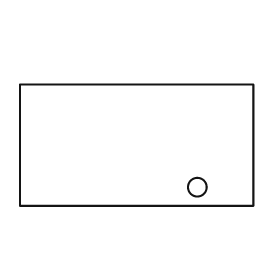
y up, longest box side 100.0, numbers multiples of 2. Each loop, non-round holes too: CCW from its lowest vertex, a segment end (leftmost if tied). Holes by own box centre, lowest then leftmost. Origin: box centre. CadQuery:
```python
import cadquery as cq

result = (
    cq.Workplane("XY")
    .moveTo(-50.0, -26.0)
    .lineTo(50.0, -26.0)
    .lineTo(50.0, 26.0)
    .lineTo(-50.0, 26.0)
    .close()
    .moveTo(26.0, -18.0)
    .circle(4.0)
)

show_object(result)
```